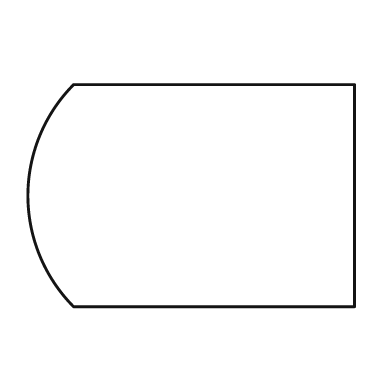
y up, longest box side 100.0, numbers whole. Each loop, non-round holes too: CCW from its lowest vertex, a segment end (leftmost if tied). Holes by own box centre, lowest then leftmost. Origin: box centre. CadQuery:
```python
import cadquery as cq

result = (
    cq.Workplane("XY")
    .moveTo(-36.0, -34.0)
    .lineTo(50.0, -34.0)
    .lineTo(50.0, 34.0)
    .lineTo(-36.0, 34.0)
    .threePointArc((-50.0, 0.0), (-36.0, -34.0))
    .close()
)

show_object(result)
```